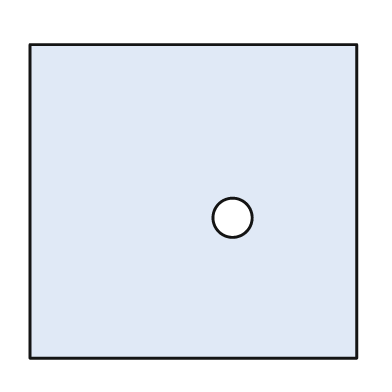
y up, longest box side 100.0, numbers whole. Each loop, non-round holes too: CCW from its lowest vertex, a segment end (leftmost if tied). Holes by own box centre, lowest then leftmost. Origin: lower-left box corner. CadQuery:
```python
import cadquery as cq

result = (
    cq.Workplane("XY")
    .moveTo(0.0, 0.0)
    .lineTo(100.0, 0.0)
    .lineTo(100.0, 96.0)
    .lineTo(0.0, 96.0)
    .close()
    .moveTo(62.0, 43.0)
    .circle(6.0)
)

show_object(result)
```